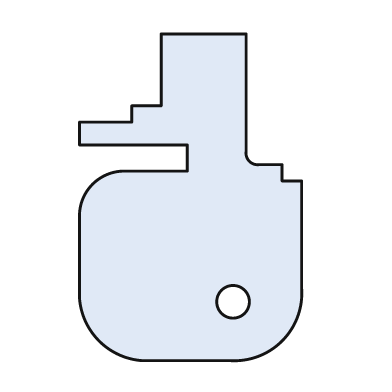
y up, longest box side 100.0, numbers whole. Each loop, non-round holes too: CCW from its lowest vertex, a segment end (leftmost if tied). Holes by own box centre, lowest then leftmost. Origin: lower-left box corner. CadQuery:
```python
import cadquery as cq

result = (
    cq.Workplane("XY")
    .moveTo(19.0, 0.0)
    .lineTo(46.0, 0.0)
    .threePointArc((62.0, 6.0), (68.0, 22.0))
    .lineTo(68.0, 55.0)
    .lineTo(62.0, 55.0)
    .lineTo(62.0, 60.0)
    .lineTo(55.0, 60.0)
    .threePointArc((52.0, 61.0), (51.0, 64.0))
    .lineTo(51.0, 100.0)
    .lineTo(25.0, 100.0)
    .lineTo(25.0, 78.0)
    .lineTo(16.0, 78.0)
    .lineTo(16.0, 73.0)
    .lineTo(0.0, 73.0)
    .lineTo(0.0, 66.0)
    .lineTo(33.0, 66.0)
    .lineTo(33.0, 58.0)
    .lineTo(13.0, 58.0)
    .threePointArc((4.0, 54.0), (0.0, 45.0))
    .lineTo(0.0, 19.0)
    .threePointArc((6.0, 6.0), (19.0, 0.0))
    .close()
    .moveTo(47.0, 18.0)
    .circle(5.0)
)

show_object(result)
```